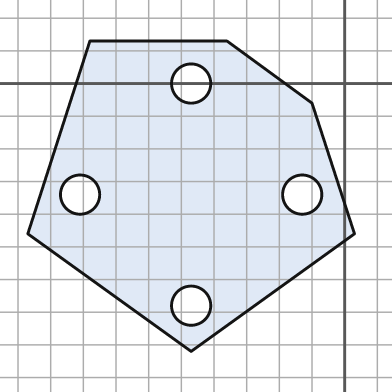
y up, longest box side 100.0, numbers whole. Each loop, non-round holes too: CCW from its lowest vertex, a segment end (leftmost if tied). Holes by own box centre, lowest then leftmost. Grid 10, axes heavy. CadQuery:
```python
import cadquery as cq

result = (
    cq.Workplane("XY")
    .moveTo(-47.0, -82.0)
    .lineTo(3.0, -46.0)
    .lineTo(-10.0, -6.0)
    .lineTo(-36.0, 13.0)
    .lineTo(-78.0, 13.0)
    .lineTo(-97.0, -46.0)
    .close()
    .moveTo(-47.0, -68.0)
    .circle(6.0)
    .moveTo(-81.0, -34.0)
    .circle(6.0)
    .moveTo(-13.0, -34.0)
    .circle(6.0)
    .moveTo(-47.0, 0.0)
    .circle(6.0)
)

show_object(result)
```